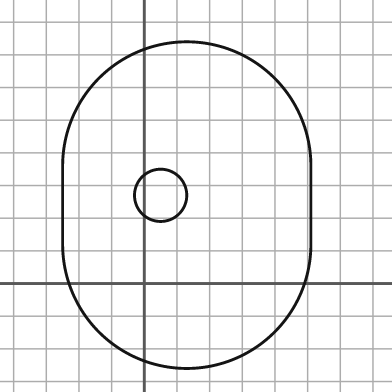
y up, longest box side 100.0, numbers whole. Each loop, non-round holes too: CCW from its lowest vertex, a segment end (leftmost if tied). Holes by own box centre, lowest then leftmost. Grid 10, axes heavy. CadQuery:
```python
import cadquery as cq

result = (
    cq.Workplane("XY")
    .moveTo(-25.0, 12.0)
    .threePointArc((13.0, -26.0), (51.0, 12.0))
    .lineTo(51.0, 36.0)
    .threePointArc((13.0, 74.0), (-25.0, 36.0))
    .close()
    .moveTo(5.0, 27.0)
    .circle(8.0)
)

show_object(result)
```